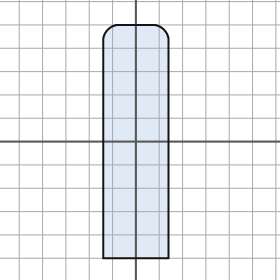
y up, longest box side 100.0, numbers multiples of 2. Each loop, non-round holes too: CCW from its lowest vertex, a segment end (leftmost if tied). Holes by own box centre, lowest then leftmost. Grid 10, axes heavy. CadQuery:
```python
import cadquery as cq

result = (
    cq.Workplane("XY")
    .moveTo(-14.0, -50.0)
    .lineTo(14.0, -50.0)
    .lineTo(14.0, 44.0)
    .threePointArc((12.0, 48.0), (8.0, 50.0))
    .lineTo(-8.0, 50.0)
    .threePointArc((-12.0, 48.0), (-14.0, 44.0))
    .close()
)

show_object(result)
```